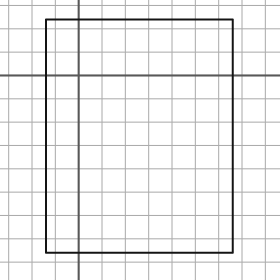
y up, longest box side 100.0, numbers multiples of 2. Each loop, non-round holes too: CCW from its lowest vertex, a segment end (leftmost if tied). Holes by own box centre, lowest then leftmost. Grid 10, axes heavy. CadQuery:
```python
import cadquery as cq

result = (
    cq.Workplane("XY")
    .moveTo(-14.0, -76.0)
    .lineTo(66.0, -76.0)
    .lineTo(66.0, 24.0)
    .lineTo(-14.0, 24.0)
    .close()
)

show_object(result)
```